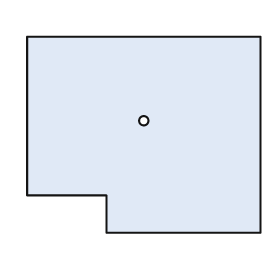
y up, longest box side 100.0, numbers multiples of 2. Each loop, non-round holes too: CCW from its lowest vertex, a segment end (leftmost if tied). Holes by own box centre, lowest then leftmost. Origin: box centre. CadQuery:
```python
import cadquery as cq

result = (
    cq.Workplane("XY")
    .moveTo(-16.0, -42.0)
    .lineTo(50.0, -42.0)
    .lineTo(50.0, 42.0)
    .lineTo(-50.0, 42.0)
    .lineTo(-50.0, -26.0)
    .lineTo(-16.0, -26.0)
    .close()
    .moveTo(0.0, 6.0)
    .circle(2.0)
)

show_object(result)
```